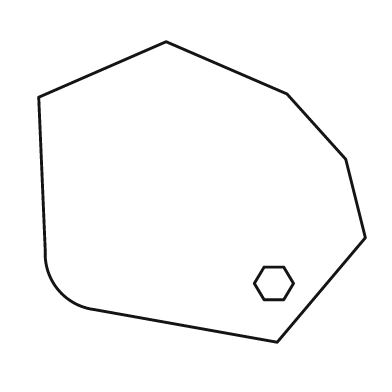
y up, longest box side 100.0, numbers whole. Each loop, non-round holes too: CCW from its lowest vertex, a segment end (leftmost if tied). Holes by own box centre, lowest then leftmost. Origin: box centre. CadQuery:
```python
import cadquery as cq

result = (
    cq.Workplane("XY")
    .moveTo(23.0, -46.0)
    .lineTo(50.0, -14.0)
    .lineTo(44.0, 10.0)
    .lineTo(26.0, 30.0)
    .lineTo(-11.0, 46.0)
    .lineTo(-50.0, 29.0)
    .lineTo(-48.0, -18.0)
    .threePointArc((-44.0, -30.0), (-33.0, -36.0))
    .close()
    .moveTo(19.0, -33.0)
    .lineTo(25.0, -33.0)
    .lineTo(28.0, -28.0)
    .lineTo(25.0, -23.0)
    .lineTo(19.0, -23.0)
    .lineTo(16.0, -28.0)
    .close()
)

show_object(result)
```